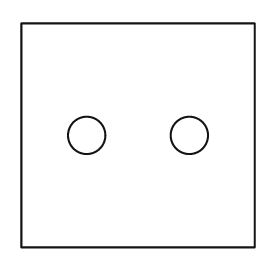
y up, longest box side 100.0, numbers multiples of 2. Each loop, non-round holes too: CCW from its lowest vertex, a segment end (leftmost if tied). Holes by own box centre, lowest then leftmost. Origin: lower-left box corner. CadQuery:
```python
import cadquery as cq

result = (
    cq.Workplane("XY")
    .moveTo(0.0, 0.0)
    .lineTo(100.0, 0.0)
    .lineTo(100.0, 96.0)
    .lineTo(0.0, 96.0)
    .close()
    .moveTo(28.0, 48.0)
    .circle(8.0)
    .moveTo(72.0, 48.0)
    .circle(8.0)
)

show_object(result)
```